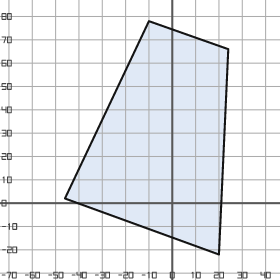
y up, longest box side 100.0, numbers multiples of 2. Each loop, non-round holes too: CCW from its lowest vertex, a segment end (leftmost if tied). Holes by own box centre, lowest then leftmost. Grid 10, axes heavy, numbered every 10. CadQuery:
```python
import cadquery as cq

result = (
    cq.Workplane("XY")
    .moveTo(20.0, -22.0)
    .lineTo(24.0, 66.0)
    .lineTo(-10.0, 78.0)
    .lineTo(-46.0, 2.0)
    .close()
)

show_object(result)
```